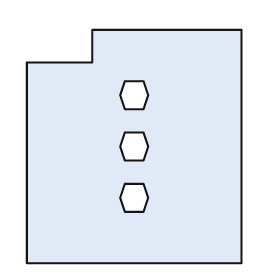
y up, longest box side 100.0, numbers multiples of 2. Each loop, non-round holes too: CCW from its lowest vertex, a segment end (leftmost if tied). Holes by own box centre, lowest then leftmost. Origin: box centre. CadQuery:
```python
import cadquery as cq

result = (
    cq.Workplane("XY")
    .moveTo(-46.0, -50.0)
    .lineTo(46.0, -50.0)
    .lineTo(46.0, 50.0)
    .lineTo(-18.0, 50.0)
    .lineTo(-18.0, 36.0)
    .lineTo(-46.0, 36.0)
    .close()
    .moveTo(-4.0, -28.0)
    .lineTo(4.0, -28.0)
    .lineTo(6.0, -22.0)
    .lineTo(4.0, -16.0)
    .lineTo(-4.0, -16.0)
    .lineTo(-6.0, -22.0)
    .close()
    .moveTo(-4.0, -6.0)
    .lineTo(4.0, -6.0)
    .lineTo(6.0, 0.0)
    .lineTo(4.0, 6.0)
    .lineTo(-4.0, 6.0)
    .lineTo(-6.0, 0.0)
    .close()
    .moveTo(-4.0, 16.0)
    .lineTo(4.0, 16.0)
    .lineTo(6.0, 22.0)
    .lineTo(4.0, 28.0)
    .lineTo(-4.0, 28.0)
    .lineTo(-6.0, 22.0)
    .close()
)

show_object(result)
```